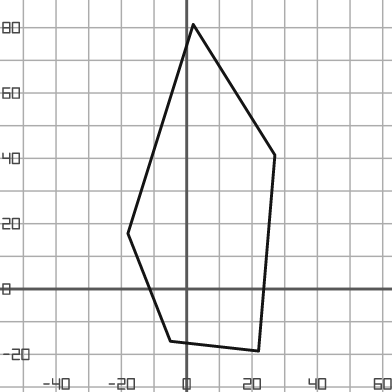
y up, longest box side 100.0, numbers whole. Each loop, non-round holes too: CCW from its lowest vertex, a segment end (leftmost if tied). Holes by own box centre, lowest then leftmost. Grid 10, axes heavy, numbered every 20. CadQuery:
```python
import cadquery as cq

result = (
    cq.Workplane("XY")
    .moveTo(22.0, -19.0)
    .lineTo(27.0, 41.0)
    .lineTo(2.0, 81.0)
    .lineTo(-18.0, 17.0)
    .lineTo(-5.0, -16.0)
    .close()
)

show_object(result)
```